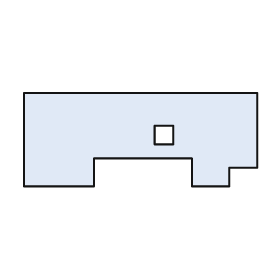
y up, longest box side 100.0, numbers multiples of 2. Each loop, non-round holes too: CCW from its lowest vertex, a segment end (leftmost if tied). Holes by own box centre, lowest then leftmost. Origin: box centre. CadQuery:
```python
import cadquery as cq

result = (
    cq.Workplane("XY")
    .moveTo(-50.0, -20.0)
    .lineTo(-20.0, -20.0)
    .lineTo(-20.0, -8.0)
    .lineTo(22.0, -8.0)
    .lineTo(22.0, -20.0)
    .lineTo(38.0, -20.0)
    .lineTo(38.0, -12.0)
    .lineTo(50.0, -12.0)
    .lineTo(50.0, 20.0)
    .lineTo(-50.0, 20.0)
    .close()
    .moveTo(6.0, -2.0)
    .lineTo(14.0, -2.0)
    .lineTo(14.0, 6.0)
    .lineTo(6.0, 6.0)
    .close()
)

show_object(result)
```